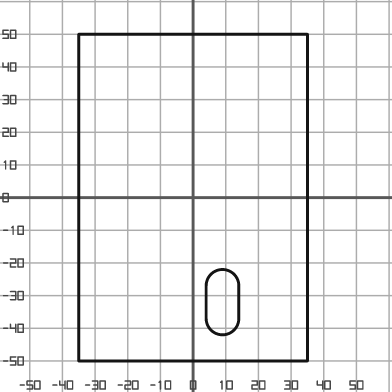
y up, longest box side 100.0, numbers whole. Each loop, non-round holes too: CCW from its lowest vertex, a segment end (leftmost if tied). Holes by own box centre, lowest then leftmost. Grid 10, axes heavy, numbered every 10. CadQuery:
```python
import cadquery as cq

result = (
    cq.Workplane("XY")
    .moveTo(-35.0, -50.0)
    .lineTo(35.0, -50.0)
    .lineTo(35.0, 50.0)
    .lineTo(-35.0, 50.0)
    .close()
    .moveTo(4.0, -37.0)
    .threePointArc((9.0, -42.0), (14.0, -37.0))
    .lineTo(14.0, -27.0)
    .threePointArc((9.0, -22.0), (4.0, -27.0))
    .close()
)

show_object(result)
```